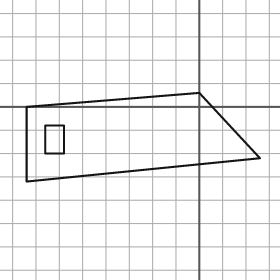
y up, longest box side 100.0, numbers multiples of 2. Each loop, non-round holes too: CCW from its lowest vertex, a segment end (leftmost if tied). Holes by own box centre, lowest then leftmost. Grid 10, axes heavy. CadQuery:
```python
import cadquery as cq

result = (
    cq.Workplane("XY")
    .moveTo(-74.0, -32.0)
    .lineTo(26.0, -22.0)
    .lineTo(0.0, 6.0)
    .lineTo(-74.0, 0.0)
    .close()
    .moveTo(-66.0, -20.0)
    .lineTo(-58.0, -20.0)
    .lineTo(-58.0, -8.0)
    .lineTo(-66.0, -8.0)
    .close()
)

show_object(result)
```